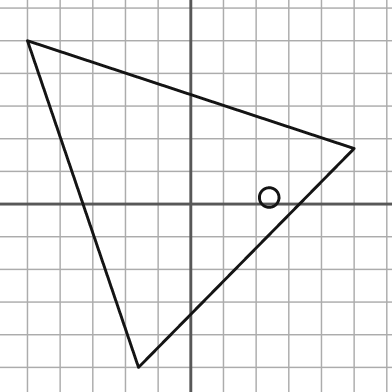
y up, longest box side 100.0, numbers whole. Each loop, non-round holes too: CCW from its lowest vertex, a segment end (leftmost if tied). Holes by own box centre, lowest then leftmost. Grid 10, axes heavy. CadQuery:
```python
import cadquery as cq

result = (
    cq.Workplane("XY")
    .moveTo(-16.0, -50.0)
    .lineTo(50.0, 17.0)
    .lineTo(-50.0, 50.0)
    .close()
    .moveTo(24.0, 2.0)
    .circle(3.0)
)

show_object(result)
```